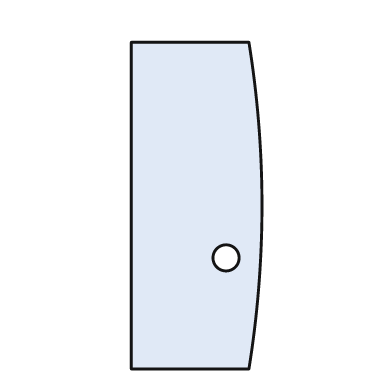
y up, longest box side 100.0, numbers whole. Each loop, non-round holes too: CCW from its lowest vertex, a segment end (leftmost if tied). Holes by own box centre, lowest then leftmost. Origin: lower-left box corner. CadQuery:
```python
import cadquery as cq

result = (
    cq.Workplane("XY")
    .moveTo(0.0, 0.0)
    .lineTo(36.0, 0.0)
    .threePointArc((40.0, 50.0), (36.0, 100.0))
    .lineTo(0.0, 100.0)
    .close()
    .moveTo(29.0, 34.0)
    .circle(4.0)
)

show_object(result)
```